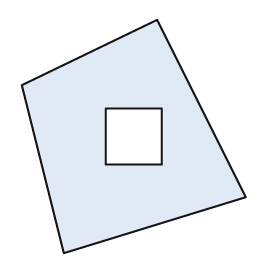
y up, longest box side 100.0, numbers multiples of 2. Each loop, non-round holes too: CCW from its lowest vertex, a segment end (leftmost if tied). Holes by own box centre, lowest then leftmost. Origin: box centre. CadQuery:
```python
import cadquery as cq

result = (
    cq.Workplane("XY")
    .moveTo(-30.0, -50.0)
    .lineTo(48.0, -26.0)
    .lineTo(10.0, 50.0)
    .lineTo(-48.0, 22.0)
    .close()
    .moveTo(-12.0, -12.0)
    .lineTo(12.0, -12.0)
    .lineTo(12.0, 12.0)
    .lineTo(-12.0, 12.0)
    .close()
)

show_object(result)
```